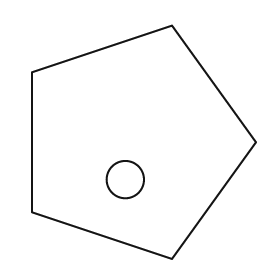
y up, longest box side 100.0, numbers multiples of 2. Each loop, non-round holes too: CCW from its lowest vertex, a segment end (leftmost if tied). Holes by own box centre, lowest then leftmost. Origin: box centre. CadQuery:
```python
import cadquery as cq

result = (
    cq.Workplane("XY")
    .moveTo(12.0, -50.0)
    .lineTo(48.0, 0.0)
    .lineTo(12.0, 50.0)
    .lineTo(-48.0, 30.0)
    .lineTo(-48.0, -30.0)
    .close()
    .moveTo(-8.0, -16.0)
    .circle(8.0)
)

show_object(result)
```